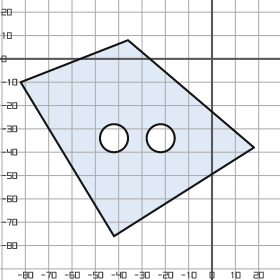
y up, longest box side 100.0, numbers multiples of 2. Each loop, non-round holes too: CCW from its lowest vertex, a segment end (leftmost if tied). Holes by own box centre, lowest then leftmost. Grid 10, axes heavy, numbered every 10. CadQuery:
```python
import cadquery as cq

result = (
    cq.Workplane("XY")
    .moveTo(-42.0, -76.0)
    .lineTo(18.0, -38.0)
    .lineTo(-36.0, 8.0)
    .lineTo(-82.0, -10.0)
    .close()
    .moveTo(-42.0, -34.0)
    .circle(6.0)
    .moveTo(-22.0, -34.0)
    .circle(6.0)
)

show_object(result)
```